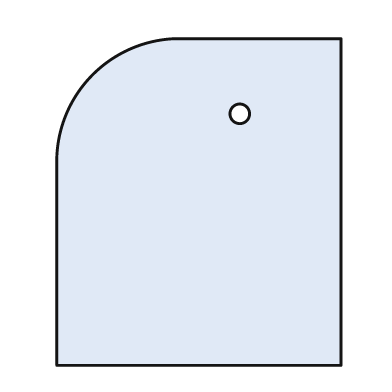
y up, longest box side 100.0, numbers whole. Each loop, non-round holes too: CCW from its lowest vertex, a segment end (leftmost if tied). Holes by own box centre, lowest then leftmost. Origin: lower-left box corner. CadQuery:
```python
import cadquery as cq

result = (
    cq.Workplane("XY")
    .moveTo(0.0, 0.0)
    .lineTo(87.0, 0.0)
    .lineTo(87.0, 100.0)
    .lineTo(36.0, 100.0)
    .threePointArc((11.0, 89.0), (0.0, 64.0))
    .close()
    .moveTo(56.0, 77.0)
    .circle(3.0)
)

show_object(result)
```